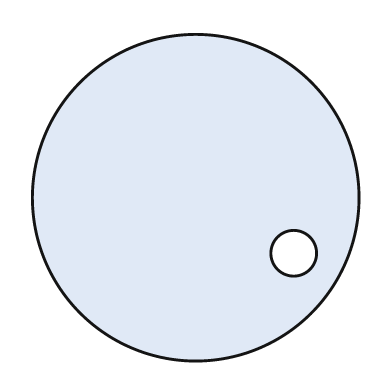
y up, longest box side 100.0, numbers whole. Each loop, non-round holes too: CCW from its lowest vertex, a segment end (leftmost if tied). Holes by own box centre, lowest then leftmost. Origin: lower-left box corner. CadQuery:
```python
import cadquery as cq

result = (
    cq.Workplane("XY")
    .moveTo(50.0, 50.0)
    .circle(50.0)
    .moveTo(80.0, 33.0)
    .circle(7.0)
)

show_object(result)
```